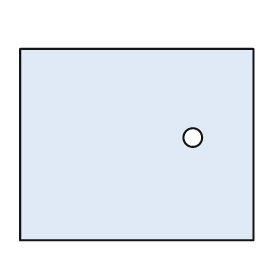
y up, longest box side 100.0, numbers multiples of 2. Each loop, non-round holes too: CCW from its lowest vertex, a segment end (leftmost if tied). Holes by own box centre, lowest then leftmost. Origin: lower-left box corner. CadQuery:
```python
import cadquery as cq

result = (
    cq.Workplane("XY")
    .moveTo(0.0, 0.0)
    .lineTo(100.0, 0.0)
    .lineTo(100.0, 82.0)
    .lineTo(0.0, 82.0)
    .close()
    .moveTo(74.0, 44.0)
    .circle(4.0)
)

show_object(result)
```